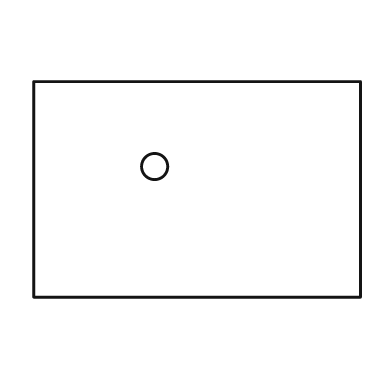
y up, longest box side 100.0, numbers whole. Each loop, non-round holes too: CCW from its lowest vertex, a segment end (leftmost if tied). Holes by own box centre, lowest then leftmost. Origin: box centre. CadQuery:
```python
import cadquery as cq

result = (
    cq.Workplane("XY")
    .moveTo(-50.0, -33.0)
    .lineTo(50.0, -33.0)
    .lineTo(50.0, 33.0)
    .lineTo(-50.0, 33.0)
    .close()
    .moveTo(-13.0, 7.0)
    .circle(4.0)
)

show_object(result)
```